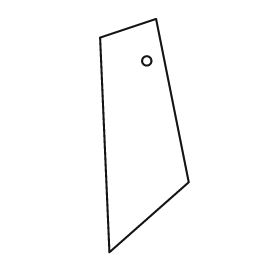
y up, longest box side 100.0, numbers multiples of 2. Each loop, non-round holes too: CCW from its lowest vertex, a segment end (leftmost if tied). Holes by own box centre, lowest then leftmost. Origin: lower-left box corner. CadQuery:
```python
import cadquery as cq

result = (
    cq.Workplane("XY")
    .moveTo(4.0, 0.0)
    .lineTo(38.0, 30.0)
    .lineTo(24.0, 100.0)
    .lineTo(0.0, 92.0)
    .close()
    .moveTo(20.0, 82.0)
    .circle(2.0)
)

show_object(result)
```